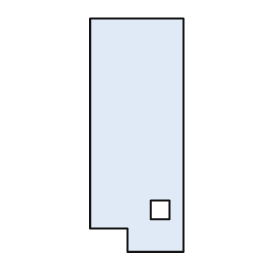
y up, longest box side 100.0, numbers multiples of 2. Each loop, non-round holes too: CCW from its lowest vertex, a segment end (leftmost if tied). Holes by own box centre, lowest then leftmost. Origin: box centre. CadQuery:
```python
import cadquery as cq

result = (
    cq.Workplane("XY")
    .moveTo(-4.0, -50.0)
    .lineTo(20.0, -50.0)
    .lineTo(20.0, 50.0)
    .lineTo(-20.0, 50.0)
    .lineTo(-20.0, -40.0)
    .lineTo(-4.0, -40.0)
    .close()
    .moveTo(6.0, -36.0)
    .lineTo(14.0, -36.0)
    .lineTo(14.0, -28.0)
    .lineTo(6.0, -28.0)
    .close()
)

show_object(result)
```